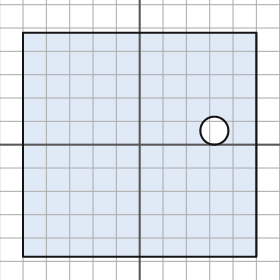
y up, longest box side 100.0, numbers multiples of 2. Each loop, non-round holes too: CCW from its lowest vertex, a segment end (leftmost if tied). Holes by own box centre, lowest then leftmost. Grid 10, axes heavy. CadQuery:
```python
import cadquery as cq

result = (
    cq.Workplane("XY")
    .moveTo(-50.0, -48.0)
    .lineTo(50.0, -48.0)
    .lineTo(50.0, 48.0)
    .lineTo(-50.0, 48.0)
    .close()
    .moveTo(32.0, 6.0)
    .circle(6.0)
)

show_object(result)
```